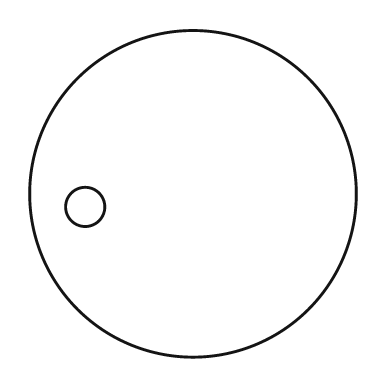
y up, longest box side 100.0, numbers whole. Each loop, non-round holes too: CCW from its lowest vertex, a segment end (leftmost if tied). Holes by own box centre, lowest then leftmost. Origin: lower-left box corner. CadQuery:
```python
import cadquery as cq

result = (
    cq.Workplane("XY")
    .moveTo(50.0, 50.0)
    .circle(50.0)
    .moveTo(17.0, 46.0)
    .circle(6.0)
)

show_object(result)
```